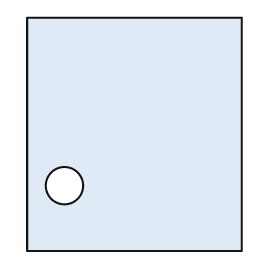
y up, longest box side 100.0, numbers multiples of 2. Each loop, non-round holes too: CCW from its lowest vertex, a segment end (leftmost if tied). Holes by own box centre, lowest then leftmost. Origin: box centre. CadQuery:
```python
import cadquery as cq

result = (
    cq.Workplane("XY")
    .moveTo(-46.0, -50.0)
    .lineTo(46.0, -50.0)
    .lineTo(46.0, 50.0)
    .lineTo(-46.0, 50.0)
    .close()
    .moveTo(-30.0, -22.0)
    .circle(8.0)
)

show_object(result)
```